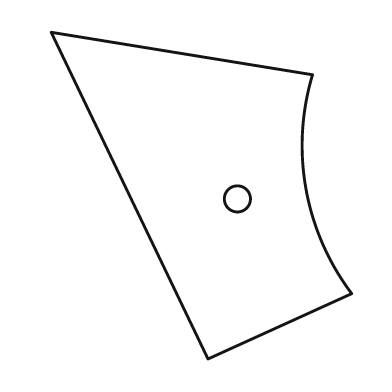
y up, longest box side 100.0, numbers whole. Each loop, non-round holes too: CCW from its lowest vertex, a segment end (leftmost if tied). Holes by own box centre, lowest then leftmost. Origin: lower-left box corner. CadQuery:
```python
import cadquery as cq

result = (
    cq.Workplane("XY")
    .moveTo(48.0, 0.0)
    .lineTo(92.0, 20.0)
    .threePointArc((78.0, 52.0), (80.0, 87.0))
    .lineTo(0.0, 100.0)
    .close()
    .moveTo(57.0, 49.0)
    .circle(4.0)
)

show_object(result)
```